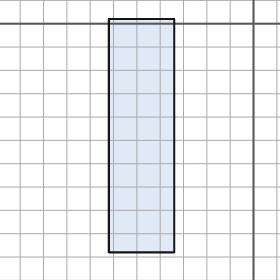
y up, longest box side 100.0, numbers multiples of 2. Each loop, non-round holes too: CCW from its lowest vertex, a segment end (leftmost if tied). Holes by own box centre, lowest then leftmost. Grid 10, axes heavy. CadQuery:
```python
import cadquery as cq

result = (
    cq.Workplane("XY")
    .moveTo(-62.0, -98.0)
    .lineTo(-34.0, -98.0)
    .lineTo(-34.0, 2.0)
    .lineTo(-62.0, 2.0)
    .close()
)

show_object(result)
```